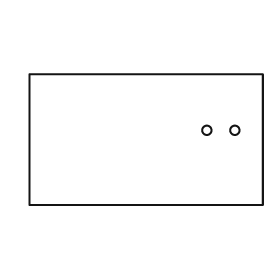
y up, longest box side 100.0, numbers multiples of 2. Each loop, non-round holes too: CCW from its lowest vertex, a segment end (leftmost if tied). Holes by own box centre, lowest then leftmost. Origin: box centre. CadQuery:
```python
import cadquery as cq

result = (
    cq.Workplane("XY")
    .moveTo(-50.0, -28.0)
    .lineTo(50.0, -28.0)
    .lineTo(50.0, 28.0)
    .lineTo(-50.0, 28.0)
    .close()
    .moveTo(26.0, 4.0)
    .circle(2.0)
    .moveTo(38.0, 4.0)
    .circle(2.0)
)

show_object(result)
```